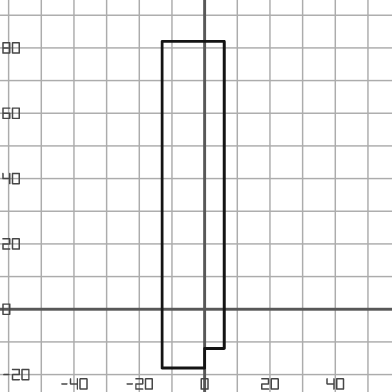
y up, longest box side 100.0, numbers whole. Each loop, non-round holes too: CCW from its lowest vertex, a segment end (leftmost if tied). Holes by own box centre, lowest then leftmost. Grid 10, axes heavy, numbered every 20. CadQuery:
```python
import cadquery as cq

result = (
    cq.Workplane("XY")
    .moveTo(-13.0, -18.0)
    .lineTo(0.0, -18.0)
    .lineTo(0.0, -12.0)
    .lineTo(6.0, -12.0)
    .lineTo(6.0, 82.0)
    .lineTo(-13.0, 82.0)
    .close()
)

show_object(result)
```